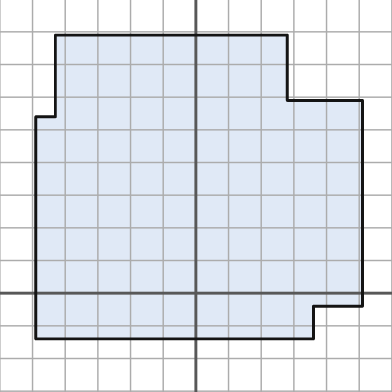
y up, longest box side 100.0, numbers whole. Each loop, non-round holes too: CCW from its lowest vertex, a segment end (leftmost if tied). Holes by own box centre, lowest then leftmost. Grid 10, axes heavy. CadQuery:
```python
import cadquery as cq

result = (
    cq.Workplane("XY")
    .moveTo(-49.0, -14.0)
    .lineTo(36.0, -14.0)
    .lineTo(36.0, -4.0)
    .lineTo(51.0, -4.0)
    .lineTo(51.0, 59.0)
    .lineTo(28.0, 59.0)
    .lineTo(28.0, 79.0)
    .lineTo(-43.0, 79.0)
    .lineTo(-43.0, 54.0)
    .lineTo(-49.0, 54.0)
    .close()
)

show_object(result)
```